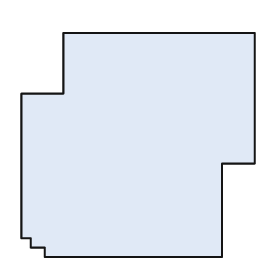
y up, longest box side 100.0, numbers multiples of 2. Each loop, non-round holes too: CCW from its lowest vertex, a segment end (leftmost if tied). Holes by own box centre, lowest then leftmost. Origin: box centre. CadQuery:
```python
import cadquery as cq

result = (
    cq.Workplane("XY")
    .moveTo(-40.0, -48.0)
    .lineTo(36.0, -48.0)
    .lineTo(36.0, -8.0)
    .lineTo(50.0, -8.0)
    .lineTo(50.0, 48.0)
    .lineTo(-32.0, 48.0)
    .lineTo(-32.0, 22.0)
    .lineTo(-50.0, 22.0)
    .lineTo(-50.0, -40.0)
    .lineTo(-46.0, -40.0)
    .lineTo(-46.0, -44.0)
    .lineTo(-40.0, -44.0)
    .close()
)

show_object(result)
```